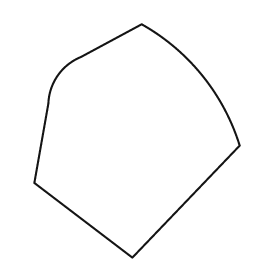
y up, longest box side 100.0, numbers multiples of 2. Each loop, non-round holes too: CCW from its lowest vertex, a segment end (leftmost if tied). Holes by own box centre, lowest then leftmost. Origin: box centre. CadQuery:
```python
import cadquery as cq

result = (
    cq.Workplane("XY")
    .moveTo(-2.0, -50.0)
    .lineTo(44.0, -2.0)
    .threePointArc((28.0, 28.0), (2.0, 50.0))
    .lineTo(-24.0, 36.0)
    .threePointArc((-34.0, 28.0), (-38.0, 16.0))
    .lineTo(-44.0, -18.0)
    .close()
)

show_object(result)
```